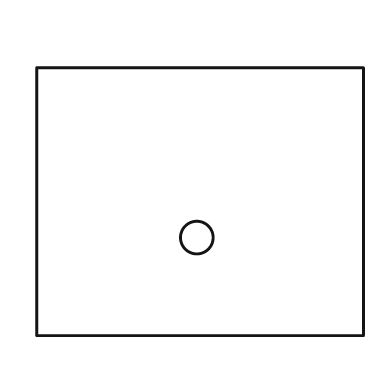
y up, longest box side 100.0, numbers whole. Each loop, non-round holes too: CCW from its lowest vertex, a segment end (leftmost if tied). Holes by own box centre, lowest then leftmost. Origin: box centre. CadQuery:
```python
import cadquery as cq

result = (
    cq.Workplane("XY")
    .moveTo(-50.0, -41.0)
    .lineTo(50.0, -41.0)
    .lineTo(50.0, 41.0)
    .lineTo(-50.0, 41.0)
    .close()
    .moveTo(-1.0, -11.0)
    .circle(5.0)
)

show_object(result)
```